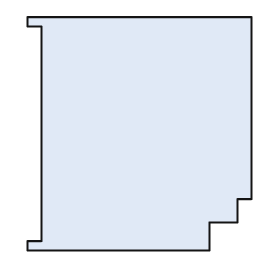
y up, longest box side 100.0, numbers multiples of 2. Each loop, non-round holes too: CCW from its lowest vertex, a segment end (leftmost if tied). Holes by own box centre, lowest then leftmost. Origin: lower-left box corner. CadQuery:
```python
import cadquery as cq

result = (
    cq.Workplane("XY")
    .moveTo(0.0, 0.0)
    .lineTo(78.0, 0.0)
    .lineTo(78.0, 12.0)
    .lineTo(90.0, 12.0)
    .lineTo(90.0, 22.0)
    .lineTo(96.0, 22.0)
    .lineTo(96.0, 100.0)
    .lineTo(0.0, 100.0)
    .lineTo(0.0, 96.0)
    .lineTo(6.0, 96.0)
    .lineTo(6.0, 4.0)
    .lineTo(0.0, 4.0)
    .close()
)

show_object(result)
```